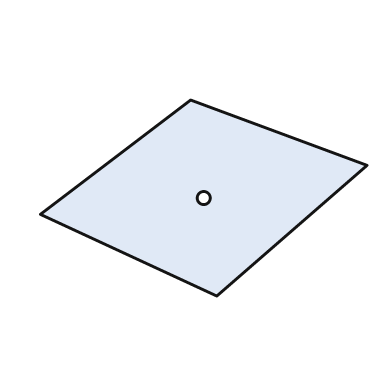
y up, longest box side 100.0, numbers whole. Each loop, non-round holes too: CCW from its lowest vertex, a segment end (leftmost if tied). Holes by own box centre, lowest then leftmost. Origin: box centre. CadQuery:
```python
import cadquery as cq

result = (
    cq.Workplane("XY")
    .moveTo(4.0, -30.0)
    .lineTo(50.0, 10.0)
    .lineTo(-4.0, 30.0)
    .lineTo(-50.0, -5.0)
    .close()
    .moveTo(0.0, 0.0)
    .circle(2.0)
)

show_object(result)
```